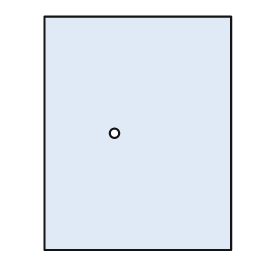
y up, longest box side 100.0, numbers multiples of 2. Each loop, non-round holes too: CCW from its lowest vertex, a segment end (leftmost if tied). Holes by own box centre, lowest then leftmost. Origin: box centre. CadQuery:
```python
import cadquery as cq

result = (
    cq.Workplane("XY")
    .moveTo(-40.0, -50.0)
    .lineTo(40.0, -50.0)
    .lineTo(40.0, 50.0)
    .lineTo(-40.0, 50.0)
    .close()
    .moveTo(-10.0, 0.0)
    .circle(2.0)
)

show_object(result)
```